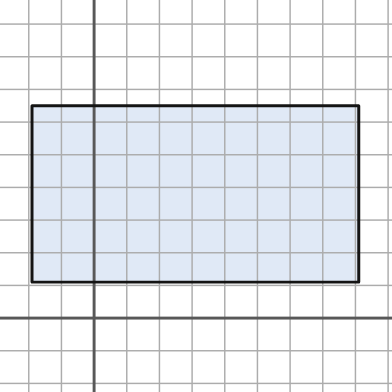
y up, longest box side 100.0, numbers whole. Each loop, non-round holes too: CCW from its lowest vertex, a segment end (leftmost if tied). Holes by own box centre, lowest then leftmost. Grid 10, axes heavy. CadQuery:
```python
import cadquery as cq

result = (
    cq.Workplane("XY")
    .moveTo(-19.0, 11.0)
    .lineTo(81.0, 11.0)
    .lineTo(81.0, 65.0)
    .lineTo(-19.0, 65.0)
    .close()
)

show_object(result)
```